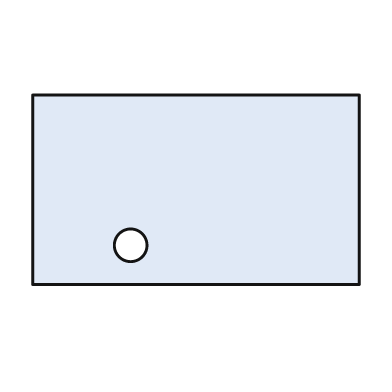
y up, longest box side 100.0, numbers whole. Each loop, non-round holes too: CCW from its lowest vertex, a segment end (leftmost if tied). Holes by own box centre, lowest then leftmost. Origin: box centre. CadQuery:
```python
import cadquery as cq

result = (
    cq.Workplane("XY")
    .moveTo(-50.0, -29.0)
    .lineTo(50.0, -29.0)
    .lineTo(50.0, 29.0)
    .lineTo(-50.0, 29.0)
    .close()
    .moveTo(-20.0, -17.0)
    .circle(5.0)
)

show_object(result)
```